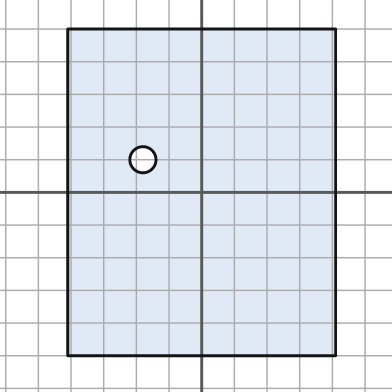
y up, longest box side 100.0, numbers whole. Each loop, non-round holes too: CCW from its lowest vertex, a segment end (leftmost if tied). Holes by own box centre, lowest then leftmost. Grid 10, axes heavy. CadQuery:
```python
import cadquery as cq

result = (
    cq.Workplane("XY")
    .moveTo(-41.0, -50.0)
    .lineTo(41.0, -50.0)
    .lineTo(41.0, 50.0)
    .lineTo(-41.0, 50.0)
    .close()
    .moveTo(-18.0, 10.0)
    .circle(4.0)
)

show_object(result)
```